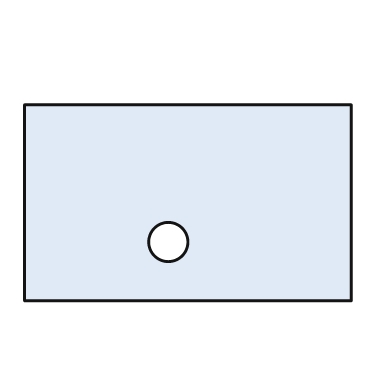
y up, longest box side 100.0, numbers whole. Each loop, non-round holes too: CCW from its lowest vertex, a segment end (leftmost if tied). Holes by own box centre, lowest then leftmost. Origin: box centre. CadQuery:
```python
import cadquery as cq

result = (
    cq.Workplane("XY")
    .moveTo(-50.0, -30.0)
    .lineTo(50.0, -30.0)
    .lineTo(50.0, 30.0)
    .lineTo(-50.0, 30.0)
    .close()
    .moveTo(-6.0, -12.0)
    .circle(6.0)
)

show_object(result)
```